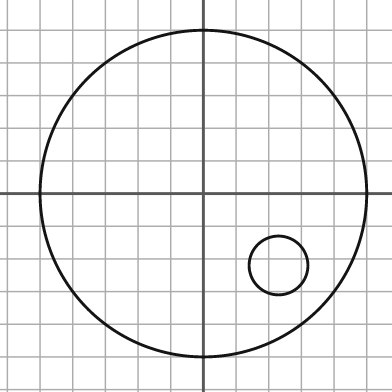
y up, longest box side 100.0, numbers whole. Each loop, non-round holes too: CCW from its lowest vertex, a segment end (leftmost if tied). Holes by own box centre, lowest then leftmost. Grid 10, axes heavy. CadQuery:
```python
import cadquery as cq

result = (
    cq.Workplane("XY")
    .moveTo(0.0, 0.0)
    .circle(50.0)
    .moveTo(23.0, -22.0)
    .circle(9.0)
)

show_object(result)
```